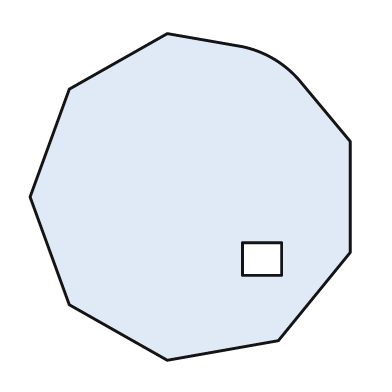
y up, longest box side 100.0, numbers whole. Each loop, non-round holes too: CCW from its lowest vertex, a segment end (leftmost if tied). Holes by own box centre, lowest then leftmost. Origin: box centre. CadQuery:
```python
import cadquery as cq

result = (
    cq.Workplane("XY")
    .moveTo(-7.0, -50.0)
    .lineTo(27.0, -44.0)
    .lineTo(49.0, -17.0)
    .lineTo(49.0, 17.0)
    .lineTo(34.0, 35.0)
    .threePointArc((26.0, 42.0), (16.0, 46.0))
    .lineTo(-7.0, 50.0)
    .lineTo(-37.0, 33.0)
    .lineTo(-49.0, 0.0)
    .lineTo(-37.0, -33.0)
    .close()
    .moveTo(16.0, -24.0)
    .lineTo(28.0, -24.0)
    .lineTo(28.0, -14.0)
    .lineTo(16.0, -14.0)
    .close()
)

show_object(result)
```